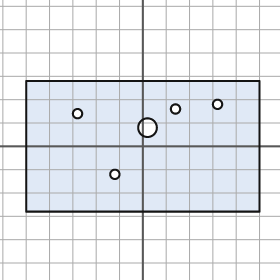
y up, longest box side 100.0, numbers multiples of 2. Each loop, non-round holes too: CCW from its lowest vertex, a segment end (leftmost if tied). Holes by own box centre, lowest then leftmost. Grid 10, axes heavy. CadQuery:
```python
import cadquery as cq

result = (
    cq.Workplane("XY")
    .moveTo(-50.0, -28.0)
    .lineTo(50.0, -28.0)
    .lineTo(50.0, 28.0)
    .lineTo(-50.0, 28.0)
    .close()
    .moveTo(-12.0, -12.0)
    .circle(2.0)
    .moveTo(2.0, 8.0)
    .circle(4.0)
    .moveTo(-28.0, 14.0)
    .circle(2.0)
    .moveTo(14.0, 16.0)
    .circle(2.0)
    .moveTo(32.0, 18.0)
    .circle(2.0)
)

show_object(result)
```